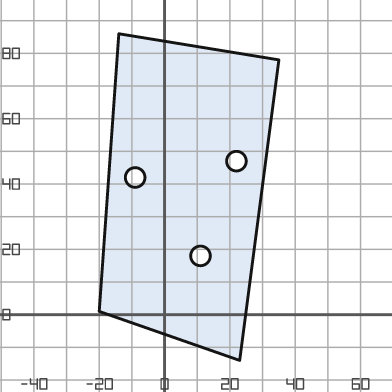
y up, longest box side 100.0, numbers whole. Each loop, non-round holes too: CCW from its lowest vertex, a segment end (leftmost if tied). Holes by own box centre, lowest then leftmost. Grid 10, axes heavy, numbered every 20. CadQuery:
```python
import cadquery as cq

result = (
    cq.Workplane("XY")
    .moveTo(23.0, -14.0)
    .lineTo(35.0, 78.0)
    .lineTo(-14.0, 86.0)
    .lineTo(-20.0, 1.0)
    .close()
    .moveTo(11.0, 18.0)
    .circle(3.0)
    .moveTo(-9.0, 42.0)
    .circle(3.0)
    .moveTo(22.0, 47.0)
    .circle(3.0)
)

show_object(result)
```